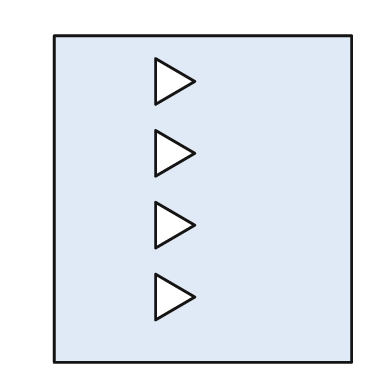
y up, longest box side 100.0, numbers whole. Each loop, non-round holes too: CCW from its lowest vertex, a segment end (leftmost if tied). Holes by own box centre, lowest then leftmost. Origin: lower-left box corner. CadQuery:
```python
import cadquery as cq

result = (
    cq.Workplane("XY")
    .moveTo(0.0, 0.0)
    .lineTo(91.0, 0.0)
    .lineTo(91.0, 100.0)
    .lineTo(0.0, 100.0)
    .close()
    .moveTo(31.0, 13.0)
    .lineTo(43.0, 20.0)
    .lineTo(31.0, 27.0)
    .close()
    .moveTo(31.0, 35.0)
    .lineTo(43.0, 42.0)
    .lineTo(31.0, 49.0)
    .close()
    .moveTo(31.0, 57.0)
    .lineTo(43.0, 64.0)
    .lineTo(31.0, 71.0)
    .close()
    .moveTo(31.0, 79.0)
    .lineTo(43.0, 86.0)
    .lineTo(31.0, 93.0)
    .close()
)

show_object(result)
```